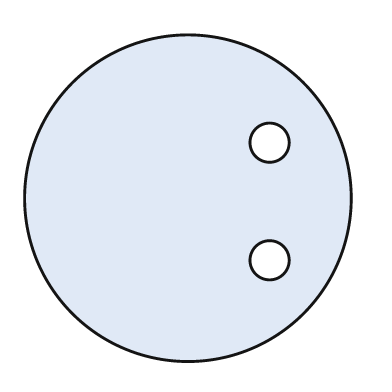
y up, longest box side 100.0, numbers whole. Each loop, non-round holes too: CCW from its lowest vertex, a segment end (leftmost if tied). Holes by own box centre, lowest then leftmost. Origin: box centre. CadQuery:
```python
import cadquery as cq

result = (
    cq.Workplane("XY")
    .moveTo(0.0, 0.0)
    .circle(50.0)
    .moveTo(25.0, -19.0)
    .circle(6.0)
    .moveTo(25.0, 17.0)
    .circle(6.0)
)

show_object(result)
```